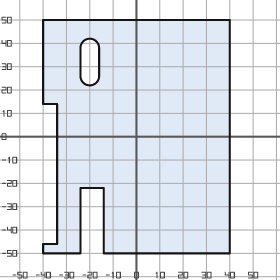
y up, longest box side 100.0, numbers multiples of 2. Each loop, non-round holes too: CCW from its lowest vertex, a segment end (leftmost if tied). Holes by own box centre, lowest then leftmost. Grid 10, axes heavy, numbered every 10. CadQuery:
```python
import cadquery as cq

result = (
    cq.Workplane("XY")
    .moveTo(-40.0, -50.0)
    .lineTo(-24.0, -50.0)
    .lineTo(-24.0, -22.0)
    .lineTo(-14.0, -22.0)
    .lineTo(-14.0, -50.0)
    .lineTo(40.0, -50.0)
    .lineTo(40.0, 50.0)
    .lineTo(-40.0, 50.0)
    .lineTo(-40.0, 14.0)
    .lineTo(-34.0, 14.0)
    .lineTo(-34.0, -46.0)
    .lineTo(-40.0, -46.0)
    .close()
    .moveTo(-24.0, 26.0)
    .threePointArc((-20.0, 22.0), (-16.0, 26.0))
    .lineTo(-16.0, 38.0)
    .threePointArc((-20.0, 42.0), (-24.0, 38.0))
    .close()
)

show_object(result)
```